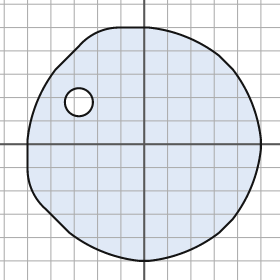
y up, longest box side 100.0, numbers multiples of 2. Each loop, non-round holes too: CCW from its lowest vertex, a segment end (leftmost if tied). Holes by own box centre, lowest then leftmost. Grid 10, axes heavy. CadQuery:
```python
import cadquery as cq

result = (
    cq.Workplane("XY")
    .moveTo(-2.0, -50.0)
    .lineTo(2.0, -50.0)
    .threePointArc((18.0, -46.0), (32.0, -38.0))
    .lineTo(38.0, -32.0)
    .threePointArc((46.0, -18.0), (50.0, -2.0))
    .lineTo(50.0, 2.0)
    .threePointArc((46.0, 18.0), (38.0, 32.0))
    .lineTo(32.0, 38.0)
    .threePointArc((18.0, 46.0), (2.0, 50.0))
    .lineTo(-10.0, 50.0)
    .threePointArc((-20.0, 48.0), (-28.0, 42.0))
    .lineTo(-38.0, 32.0)
    .threePointArc((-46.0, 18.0), (-50.0, 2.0))
    .lineTo(-50.0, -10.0)
    .threePointArc((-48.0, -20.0), (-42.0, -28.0))
    .lineTo(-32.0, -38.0)
    .threePointArc((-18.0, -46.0), (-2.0, -50.0))
    .close()
    .moveTo(-28.0, 18.0)
    .circle(6.0)
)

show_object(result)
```